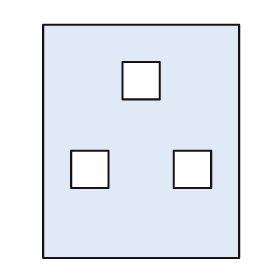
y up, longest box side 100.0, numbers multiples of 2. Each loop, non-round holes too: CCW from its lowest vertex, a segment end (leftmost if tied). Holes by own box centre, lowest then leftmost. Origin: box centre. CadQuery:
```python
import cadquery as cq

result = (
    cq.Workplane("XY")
    .moveTo(-42.0, -50.0)
    .lineTo(42.0, -50.0)
    .lineTo(42.0, 50.0)
    .lineTo(-42.0, 50.0)
    .close()
    .moveTo(-30.0, -20.0)
    .lineTo(-14.0, -20.0)
    .lineTo(-14.0, -4.0)
    .lineTo(-30.0, -4.0)
    .close()
    .moveTo(14.0, -20.0)
    .lineTo(30.0, -20.0)
    .lineTo(30.0, -4.0)
    .lineTo(14.0, -4.0)
    .close()
    .moveTo(-8.0, 18.0)
    .lineTo(8.0, 18.0)
    .lineTo(8.0, 34.0)
    .lineTo(-8.0, 34.0)
    .close()
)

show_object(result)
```